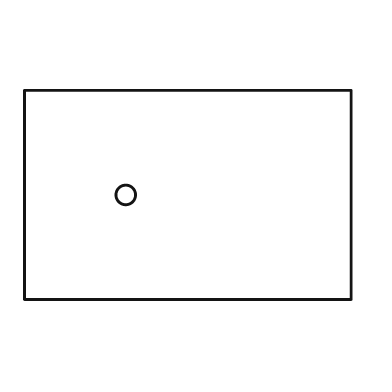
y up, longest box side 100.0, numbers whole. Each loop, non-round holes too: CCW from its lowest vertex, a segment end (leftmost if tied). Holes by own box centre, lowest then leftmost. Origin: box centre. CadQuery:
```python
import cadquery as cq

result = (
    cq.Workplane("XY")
    .moveTo(-50.0, -32.0)
    .lineTo(50.0, -32.0)
    .lineTo(50.0, 32.0)
    .lineTo(-50.0, 32.0)
    .close()
    .moveTo(-19.0, 0.0)
    .circle(3.0)
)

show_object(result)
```